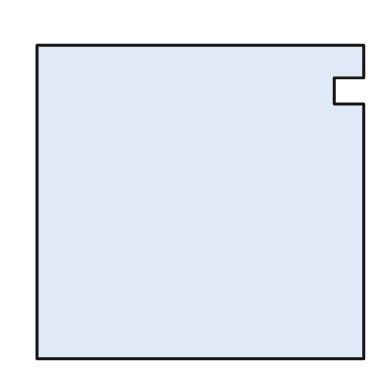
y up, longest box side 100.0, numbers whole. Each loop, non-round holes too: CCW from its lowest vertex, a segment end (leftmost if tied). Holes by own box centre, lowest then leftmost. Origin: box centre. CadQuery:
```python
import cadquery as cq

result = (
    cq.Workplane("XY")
    .moveTo(-50.0, -48.0)
    .lineTo(50.0, -48.0)
    .lineTo(50.0, 30.0)
    .lineTo(41.0, 30.0)
    .lineTo(41.0, 38.0)
    .lineTo(50.0, 38.0)
    .lineTo(50.0, 48.0)
    .lineTo(-50.0, 48.0)
    .close()
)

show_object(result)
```